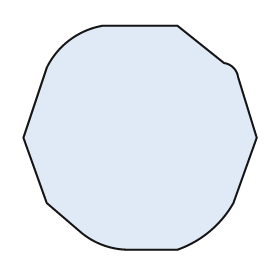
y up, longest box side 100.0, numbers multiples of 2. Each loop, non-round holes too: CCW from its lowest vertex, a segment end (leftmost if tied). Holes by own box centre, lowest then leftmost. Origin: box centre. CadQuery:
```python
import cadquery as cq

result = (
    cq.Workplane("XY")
    .moveTo(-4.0, -48.0)
    .lineTo(16.0, -48.0)
    .threePointArc((30.0, -40.0), (40.0, -28.0))
    .lineTo(50.0, 0.0)
    .lineTo(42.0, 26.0)
    .threePointArc((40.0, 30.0), (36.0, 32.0))
    .lineTo(16.0, 48.0)
    .lineTo(-16.0, 48.0)
    .threePointArc((-30.0, 42.0), (-40.0, 30.0))
    .lineTo(-50.0, 0.0)
    .lineTo(-40.0, -28.0)
    .lineTo(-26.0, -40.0)
    .threePointArc((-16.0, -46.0), (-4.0, -48.0))
    .close()
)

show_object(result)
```